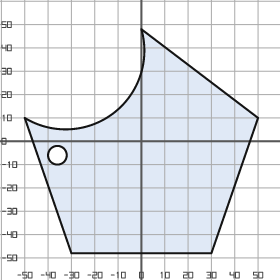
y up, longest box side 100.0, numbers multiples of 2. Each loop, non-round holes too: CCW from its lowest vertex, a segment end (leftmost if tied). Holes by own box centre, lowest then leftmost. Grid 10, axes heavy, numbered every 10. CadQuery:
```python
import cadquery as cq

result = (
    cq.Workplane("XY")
    .moveTo(-30.0, -48.0)
    .lineTo(30.0, -48.0)
    .lineTo(50.0, 10.0)
    .lineTo(0.0, 48.0)
    .threePointArc((-12.0, 12.0), (-50.0, 10.0))
    .close()
    .moveTo(-36.0, -6.0)
    .circle(4.0)
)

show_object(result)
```